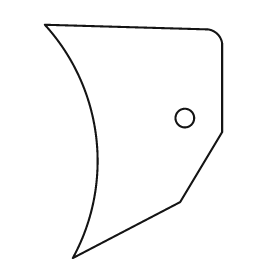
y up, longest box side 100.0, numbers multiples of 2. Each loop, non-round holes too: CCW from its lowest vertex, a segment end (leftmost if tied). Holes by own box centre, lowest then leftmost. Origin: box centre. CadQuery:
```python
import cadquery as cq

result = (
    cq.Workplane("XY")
    .moveTo(-26.0, -50.0)
    .lineTo(20.0, -26.0)
    .lineTo(38.0, 4.0)
    .lineTo(38.0, 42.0)
    .threePointArc((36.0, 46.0), (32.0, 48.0))
    .lineTo(-38.0, 50.0)
    .threePointArc((-16.0, 2.0), (-26.0, -50.0))
    .close()
    .moveTo(22.0, 10.0)
    .circle(4.0)
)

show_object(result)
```